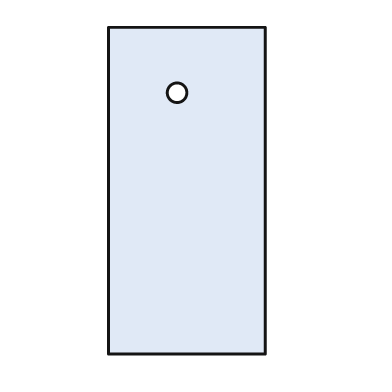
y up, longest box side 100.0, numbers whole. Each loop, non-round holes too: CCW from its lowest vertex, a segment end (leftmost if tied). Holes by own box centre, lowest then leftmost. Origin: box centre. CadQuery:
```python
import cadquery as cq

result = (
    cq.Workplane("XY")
    .moveTo(-24.0, -50.0)
    .lineTo(24.0, -50.0)
    .lineTo(24.0, 50.0)
    .lineTo(-24.0, 50.0)
    .close()
    .moveTo(-3.0, 30.0)
    .circle(3.0)
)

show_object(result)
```